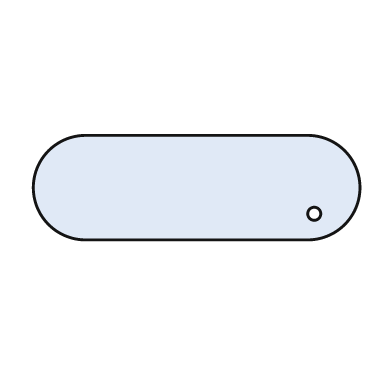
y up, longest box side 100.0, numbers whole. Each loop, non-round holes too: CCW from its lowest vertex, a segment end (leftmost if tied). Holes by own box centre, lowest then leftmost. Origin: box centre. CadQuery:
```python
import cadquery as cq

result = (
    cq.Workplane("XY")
    .moveTo(-34.0, -16.0)
    .lineTo(34.0, -16.0)
    .threePointArc((50.0, 0.0), (34.0, 16.0))
    .lineTo(-34.0, 16.0)
    .threePointArc((-50.0, 0.0), (-34.0, -16.0))
    .close()
    .moveTo(36.0, -8.0)
    .circle(2.0)
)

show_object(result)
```